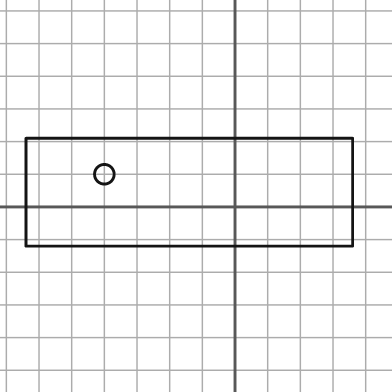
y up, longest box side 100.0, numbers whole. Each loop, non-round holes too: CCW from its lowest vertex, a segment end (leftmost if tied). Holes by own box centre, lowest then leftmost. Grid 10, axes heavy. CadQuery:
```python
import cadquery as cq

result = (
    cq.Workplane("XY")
    .moveTo(-64.0, -12.0)
    .lineTo(36.0, -12.0)
    .lineTo(36.0, 21.0)
    .lineTo(-64.0, 21.0)
    .close()
    .moveTo(-40.0, 10.0)
    .circle(3.0)
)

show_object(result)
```